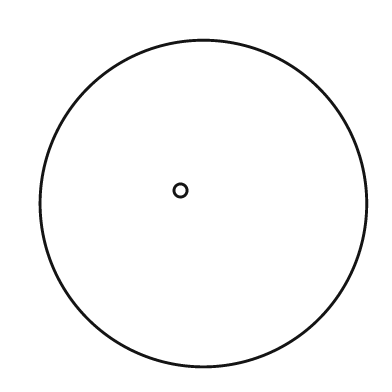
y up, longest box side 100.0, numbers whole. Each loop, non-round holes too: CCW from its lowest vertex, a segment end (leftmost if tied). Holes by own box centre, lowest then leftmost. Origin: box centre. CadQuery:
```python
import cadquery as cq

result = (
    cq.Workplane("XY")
    .moveTo(0.0, 0.0)
    .circle(50.0)
    .moveTo(-7.0, 4.0)
    .circle(2.0)
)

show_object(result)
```